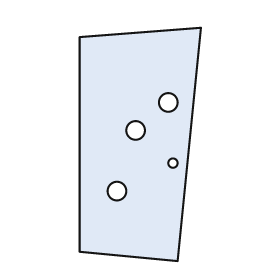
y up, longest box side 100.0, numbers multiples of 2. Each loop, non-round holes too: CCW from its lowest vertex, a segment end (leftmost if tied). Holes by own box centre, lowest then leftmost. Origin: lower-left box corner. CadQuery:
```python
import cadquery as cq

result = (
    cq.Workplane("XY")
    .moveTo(42.0, 0.0)
    .lineTo(52.0, 100.0)
    .lineTo(0.0, 96.0)
    .lineTo(0.0, 4.0)
    .close()
    .moveTo(16.0, 30.0)
    .circle(4.0)
    .moveTo(40.0, 42.0)
    .circle(2.0)
    .moveTo(24.0, 56.0)
    .circle(4.0)
    .moveTo(38.0, 68.0)
    .circle(4.0)
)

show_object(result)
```